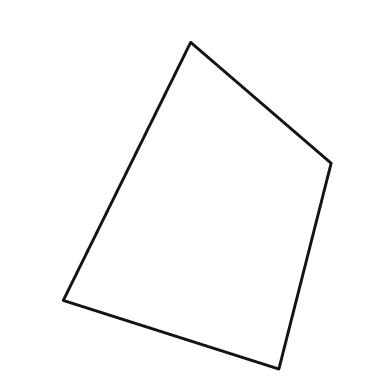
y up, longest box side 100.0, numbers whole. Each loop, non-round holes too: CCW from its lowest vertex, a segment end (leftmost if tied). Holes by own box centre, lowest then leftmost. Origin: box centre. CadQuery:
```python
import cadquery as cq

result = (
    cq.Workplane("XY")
    .moveTo(25.0, -50.0)
    .lineTo(41.0, 13.0)
    .lineTo(-2.0, 50.0)
    .lineTo(-41.0, -29.0)
    .close()
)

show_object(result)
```